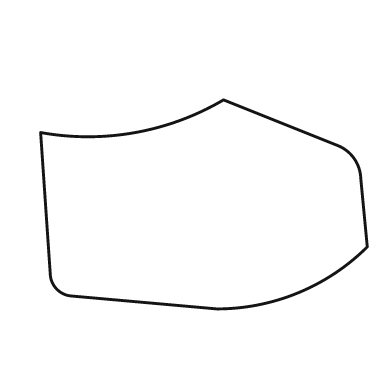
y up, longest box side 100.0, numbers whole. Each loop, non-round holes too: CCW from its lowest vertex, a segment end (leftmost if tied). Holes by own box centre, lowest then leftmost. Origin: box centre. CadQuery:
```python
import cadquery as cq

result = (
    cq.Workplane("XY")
    .moveTo(4.0, -32.0)
    .threePointArc((29.0, -27.0), (50.0, -13.0))
    .lineTo(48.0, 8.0)
    .threePointArc((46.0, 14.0), (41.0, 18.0))
    .lineTo(6.0, 32.0)
    .threePointArc((-21.0, 22.0), (-50.0, 22.0))
    .lineTo(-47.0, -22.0)
    .threePointArc((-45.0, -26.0), (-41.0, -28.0))
    .close()
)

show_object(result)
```